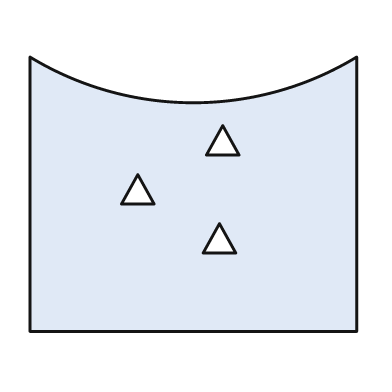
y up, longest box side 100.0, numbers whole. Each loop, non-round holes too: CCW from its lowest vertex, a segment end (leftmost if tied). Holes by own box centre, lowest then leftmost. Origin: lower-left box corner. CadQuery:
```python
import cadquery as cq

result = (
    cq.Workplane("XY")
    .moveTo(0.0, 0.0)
    .lineTo(100.0, 0.0)
    .lineTo(100.0, 84.0)
    .threePointArc((50.0, 70.0), (0.0, 84.0))
    .close()
    .moveTo(53.0, 24.0)
    .lineTo(63.0, 24.0)
    .lineTo(58.0, 33.0)
    .close()
    .moveTo(28.0, 39.0)
    .lineTo(38.0, 39.0)
    .lineTo(33.0, 48.0)
    .close()
    .moveTo(54.0, 54.0)
    .lineTo(64.0, 54.0)
    .lineTo(59.0, 63.0)
    .close()
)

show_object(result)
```